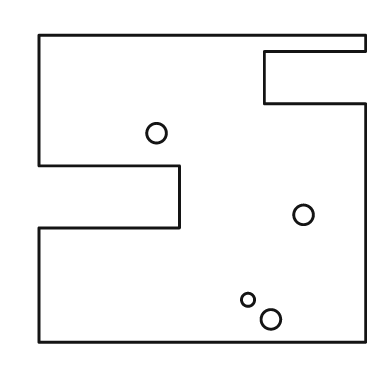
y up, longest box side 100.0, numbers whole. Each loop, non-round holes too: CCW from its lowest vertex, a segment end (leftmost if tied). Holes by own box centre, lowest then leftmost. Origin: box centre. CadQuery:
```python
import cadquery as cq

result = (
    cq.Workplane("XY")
    .moveTo(-50.0, -47.0)
    .lineTo(50.0, -47.0)
    .lineTo(50.0, 26.0)
    .lineTo(19.0, 26.0)
    .lineTo(19.0, 42.0)
    .lineTo(50.0, 42.0)
    .lineTo(50.0, 47.0)
    .lineTo(-50.0, 47.0)
    .lineTo(-50.0, 7.0)
    .lineTo(-7.0, 7.0)
    .lineTo(-7.0, -12.0)
    .lineTo(-50.0, -12.0)
    .close()
    .moveTo(21.0, -40.0)
    .circle(3.0)
    .moveTo(14.0, -34.0)
    .circle(2.0)
    .moveTo(31.0, -8.0)
    .circle(3.0)
    .moveTo(-14.0, 17.0)
    .circle(3.0)
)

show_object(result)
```